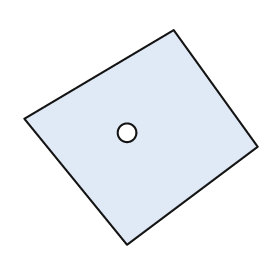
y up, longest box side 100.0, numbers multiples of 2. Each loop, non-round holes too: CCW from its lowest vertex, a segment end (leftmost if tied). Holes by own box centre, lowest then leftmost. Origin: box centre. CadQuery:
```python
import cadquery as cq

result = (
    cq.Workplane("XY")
    .moveTo(-6.0, -46.0)
    .lineTo(50.0, -4.0)
    .lineTo(14.0, 46.0)
    .lineTo(-50.0, 8.0)
    .close()
    .moveTo(-6.0, 2.0)
    .circle(4.0)
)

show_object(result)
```